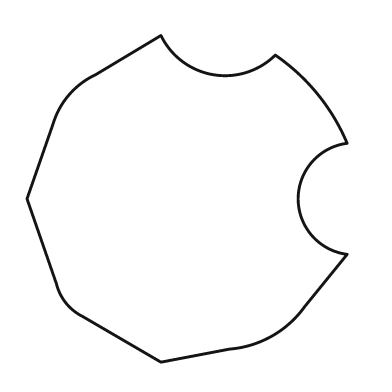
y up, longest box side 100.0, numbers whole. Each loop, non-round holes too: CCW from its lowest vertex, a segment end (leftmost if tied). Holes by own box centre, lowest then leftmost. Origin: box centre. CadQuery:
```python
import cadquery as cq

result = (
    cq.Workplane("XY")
    .moveTo(-8.0, -50.0)
    .lineTo(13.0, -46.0)
    .threePointArc((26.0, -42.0), (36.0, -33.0))
    .lineTo(49.0, -17.0)
    .threePointArc((34.0, 0.0), (49.0, 17.0))
    .threePointArc((40.0, 32.0), (27.0, 44.0))
    .threePointArc((8.0, 38.0), (-8.0, 50.0))
    .lineTo(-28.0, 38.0)
    .threePointArc((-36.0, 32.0), (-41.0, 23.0))
    .lineTo(-49.0, 0.0)
    .lineTo(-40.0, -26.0)
    .threePointArc((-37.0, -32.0), (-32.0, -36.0))
    .close()
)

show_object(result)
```